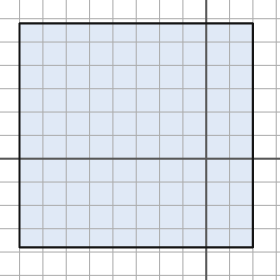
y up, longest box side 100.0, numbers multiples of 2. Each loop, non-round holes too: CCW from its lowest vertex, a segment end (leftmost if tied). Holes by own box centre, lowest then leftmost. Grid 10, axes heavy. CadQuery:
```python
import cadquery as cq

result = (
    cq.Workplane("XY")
    .moveTo(-80.0, -38.0)
    .lineTo(20.0, -38.0)
    .lineTo(20.0, 58.0)
    .lineTo(-80.0, 58.0)
    .close()
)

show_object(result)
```